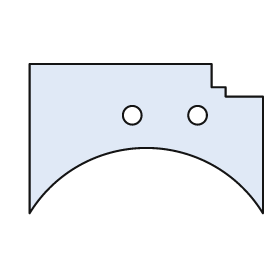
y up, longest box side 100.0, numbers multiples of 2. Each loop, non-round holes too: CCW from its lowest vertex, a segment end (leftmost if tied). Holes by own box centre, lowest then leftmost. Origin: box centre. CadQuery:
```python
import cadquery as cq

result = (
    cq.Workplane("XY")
    .moveTo(-50.0, -32.0)
    .threePointArc((0.0, -4.0), (50.0, -32.0))
    .lineTo(50.0, 18.0)
    .lineTo(34.0, 18.0)
    .lineTo(34.0, 22.0)
    .lineTo(28.0, 22.0)
    .lineTo(28.0, 32.0)
    .lineTo(-50.0, 32.0)
    .close()
    .moveTo(-6.0, 10.0)
    .circle(4.0)
    .moveTo(22.0, 10.0)
    .circle(4.0)
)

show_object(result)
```